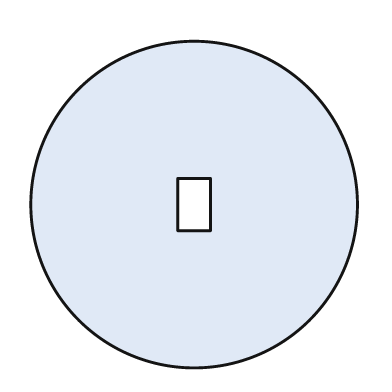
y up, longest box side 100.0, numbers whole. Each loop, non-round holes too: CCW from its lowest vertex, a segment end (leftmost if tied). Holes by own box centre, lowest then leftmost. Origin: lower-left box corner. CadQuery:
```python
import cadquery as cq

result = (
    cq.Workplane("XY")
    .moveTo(50.0, 50.0)
    .circle(50.0)
    .moveTo(45.0, 42.0)
    .lineTo(55.0, 42.0)
    .lineTo(55.0, 58.0)
    .lineTo(45.0, 58.0)
    .close()
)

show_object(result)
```